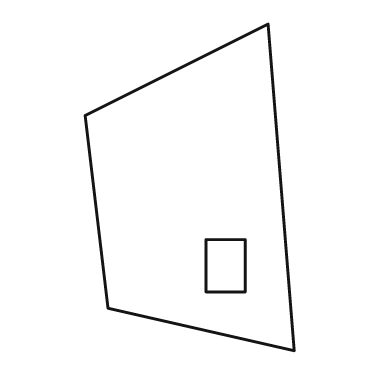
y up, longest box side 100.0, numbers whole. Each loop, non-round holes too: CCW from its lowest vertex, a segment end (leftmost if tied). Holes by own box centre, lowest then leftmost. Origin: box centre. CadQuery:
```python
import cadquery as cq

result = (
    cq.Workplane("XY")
    .moveTo(32.0, -50.0)
    .lineTo(24.0, 50.0)
    .lineTo(-32.0, 22.0)
    .lineTo(-25.0, -37.0)
    .close()
    .moveTo(5.0, -32.0)
    .lineTo(17.0, -32.0)
    .lineTo(17.0, -16.0)
    .lineTo(5.0, -16.0)
    .close()
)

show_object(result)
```